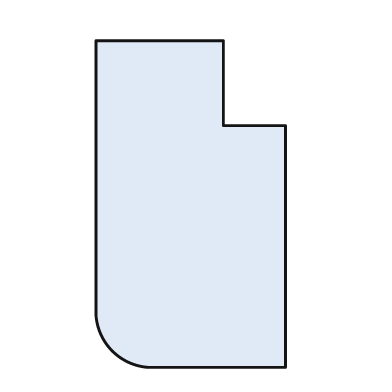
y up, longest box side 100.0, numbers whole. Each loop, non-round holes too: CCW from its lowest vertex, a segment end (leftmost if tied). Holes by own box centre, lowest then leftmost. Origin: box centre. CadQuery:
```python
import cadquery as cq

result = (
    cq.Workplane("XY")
    .moveTo(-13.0, -50.0)
    .lineTo(29.0, -50.0)
    .lineTo(29.0, 24.0)
    .lineTo(10.0, 24.0)
    .lineTo(10.0, 50.0)
    .lineTo(-29.0, 50.0)
    .lineTo(-29.0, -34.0)
    .threePointArc((-24.0, -45.0), (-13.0, -50.0))
    .close()
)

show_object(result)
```